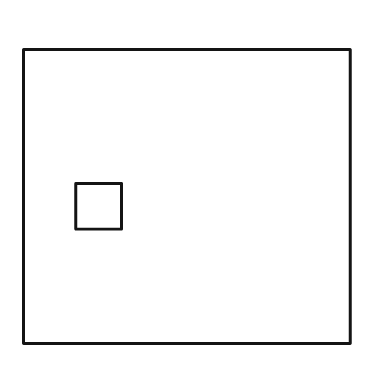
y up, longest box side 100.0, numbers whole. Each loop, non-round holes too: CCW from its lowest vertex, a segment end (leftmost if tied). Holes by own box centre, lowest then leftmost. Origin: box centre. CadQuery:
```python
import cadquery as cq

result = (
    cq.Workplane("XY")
    .moveTo(-50.0, -45.0)
    .lineTo(50.0, -45.0)
    .lineTo(50.0, 45.0)
    .lineTo(-50.0, 45.0)
    .close()
    .moveTo(-34.0, -10.0)
    .lineTo(-20.0, -10.0)
    .lineTo(-20.0, 4.0)
    .lineTo(-34.0, 4.0)
    .close()
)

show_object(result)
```